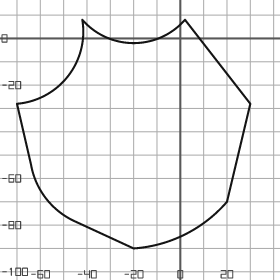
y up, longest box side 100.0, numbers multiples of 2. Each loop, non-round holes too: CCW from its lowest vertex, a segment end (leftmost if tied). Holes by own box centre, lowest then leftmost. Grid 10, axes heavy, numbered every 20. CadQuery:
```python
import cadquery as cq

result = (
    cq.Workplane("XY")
    .moveTo(-20.0, -90.0)
    .threePointArc((2.0, -84.0), (20.0, -70.0))
    .lineTo(30.0, -28.0)
    .lineTo(2.0, 8.0)
    .threePointArc((-20.0, -2.0), (-42.0, 8.0))
    .threePointArc((-48.0, -16.0), (-70.0, -28.0))
    .lineTo(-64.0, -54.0)
    .threePointArc((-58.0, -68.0), (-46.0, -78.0))
    .close()
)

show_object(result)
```